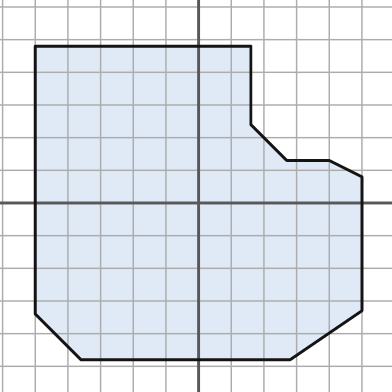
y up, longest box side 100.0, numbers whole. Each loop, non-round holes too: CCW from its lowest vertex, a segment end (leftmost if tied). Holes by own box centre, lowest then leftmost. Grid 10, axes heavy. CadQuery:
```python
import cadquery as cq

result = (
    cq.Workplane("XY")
    .moveTo(-36.0, -48.0)
    .lineTo(28.0, -48.0)
    .lineTo(50.0, -33.0)
    .lineTo(50.0, 8.0)
    .lineTo(40.0, 13.0)
    .lineTo(27.0, 13.0)
    .lineTo(16.0, 24.0)
    .lineTo(16.0, 48.0)
    .lineTo(-50.0, 48.0)
    .lineTo(-50.0, -34.0)
    .close()
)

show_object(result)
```